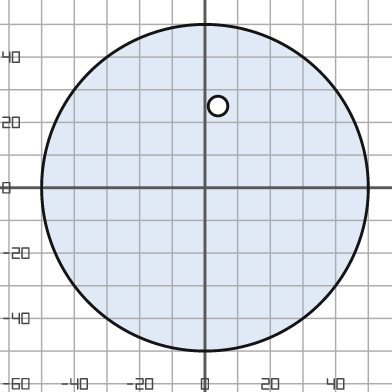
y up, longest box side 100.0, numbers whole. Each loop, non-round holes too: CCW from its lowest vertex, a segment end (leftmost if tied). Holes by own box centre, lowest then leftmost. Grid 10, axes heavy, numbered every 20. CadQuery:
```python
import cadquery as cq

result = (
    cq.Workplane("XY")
    .moveTo(0.0, 0.0)
    .circle(50.0)
    .moveTo(4.0, 25.0)
    .circle(3.0)
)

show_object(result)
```